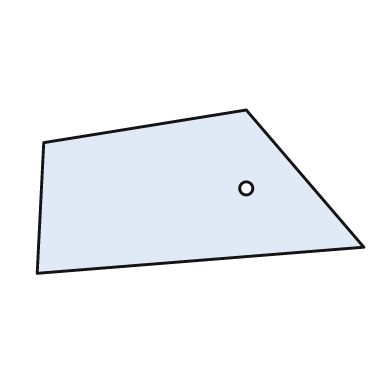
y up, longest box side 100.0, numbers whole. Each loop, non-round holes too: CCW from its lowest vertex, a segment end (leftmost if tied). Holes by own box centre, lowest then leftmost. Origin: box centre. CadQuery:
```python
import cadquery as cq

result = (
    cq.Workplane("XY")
    .moveTo(-50.0, -25.0)
    .lineTo(50.0, -17.0)
    .lineTo(14.0, 25.0)
    .lineTo(-48.0, 15.0)
    .close()
    .moveTo(14.0, 1.0)
    .circle(2.0)
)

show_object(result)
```